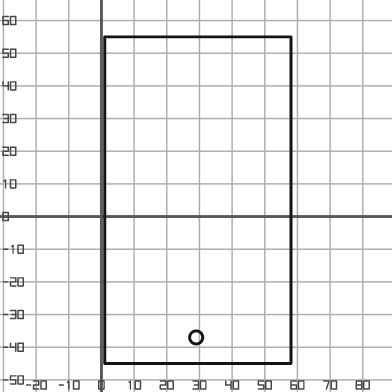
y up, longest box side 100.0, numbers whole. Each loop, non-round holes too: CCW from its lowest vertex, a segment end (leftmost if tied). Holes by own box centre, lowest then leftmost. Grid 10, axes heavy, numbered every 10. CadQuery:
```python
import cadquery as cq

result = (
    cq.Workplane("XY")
    .moveTo(1.0, -45.0)
    .lineTo(58.0, -45.0)
    .lineTo(58.0, 55.0)
    .lineTo(1.0, 55.0)
    .close()
    .moveTo(29.0, -37.0)
    .circle(2.0)
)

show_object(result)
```